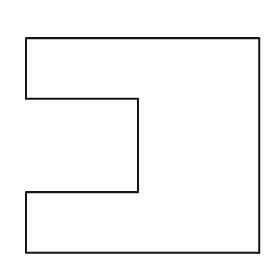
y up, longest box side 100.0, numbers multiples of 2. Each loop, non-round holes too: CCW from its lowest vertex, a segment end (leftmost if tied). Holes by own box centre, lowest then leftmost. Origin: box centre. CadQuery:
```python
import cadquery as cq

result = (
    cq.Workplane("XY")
    .moveTo(-50.0, -46.0)
    .lineTo(50.0, -46.0)
    .lineTo(50.0, 46.0)
    .lineTo(-50.0, 46.0)
    .lineTo(-50.0, 20.0)
    .lineTo(-2.0, 20.0)
    .lineTo(-2.0, -20.0)
    .lineTo(-50.0, -20.0)
    .close()
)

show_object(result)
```